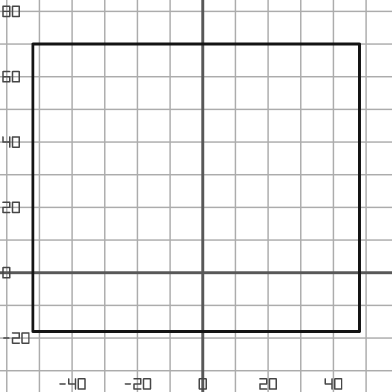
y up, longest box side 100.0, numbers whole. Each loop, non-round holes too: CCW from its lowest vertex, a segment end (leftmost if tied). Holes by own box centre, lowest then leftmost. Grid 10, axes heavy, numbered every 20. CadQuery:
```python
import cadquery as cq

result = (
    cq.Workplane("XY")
    .moveTo(-52.0, -18.0)
    .lineTo(48.0, -18.0)
    .lineTo(48.0, 70.0)
    .lineTo(-52.0, 70.0)
    .close()
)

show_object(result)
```